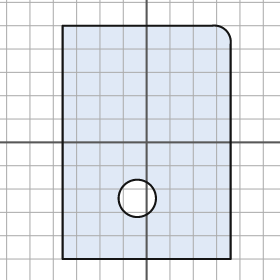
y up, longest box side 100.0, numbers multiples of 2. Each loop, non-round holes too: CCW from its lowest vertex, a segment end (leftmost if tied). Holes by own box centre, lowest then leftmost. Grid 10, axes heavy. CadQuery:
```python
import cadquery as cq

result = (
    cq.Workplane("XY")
    .moveTo(-36.0, -50.0)
    .lineTo(36.0, -50.0)
    .lineTo(36.0, 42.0)
    .threePointArc((34.0, 48.0), (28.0, 50.0))
    .lineTo(-36.0, 50.0)
    .close()
    .moveTo(-4.0, -24.0)
    .circle(8.0)
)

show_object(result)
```